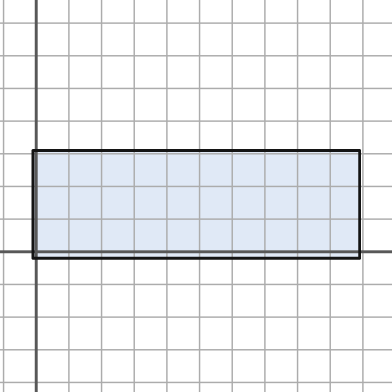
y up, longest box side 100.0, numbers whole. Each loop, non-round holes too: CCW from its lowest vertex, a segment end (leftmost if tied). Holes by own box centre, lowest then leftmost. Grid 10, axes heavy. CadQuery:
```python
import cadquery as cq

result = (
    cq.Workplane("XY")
    .moveTo(-1.0, -2.0)
    .lineTo(99.0, -2.0)
    .lineTo(99.0, 31.0)
    .lineTo(-1.0, 31.0)
    .close()
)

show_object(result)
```